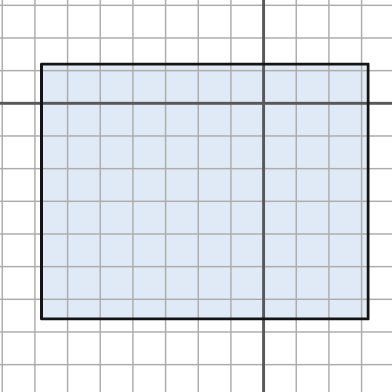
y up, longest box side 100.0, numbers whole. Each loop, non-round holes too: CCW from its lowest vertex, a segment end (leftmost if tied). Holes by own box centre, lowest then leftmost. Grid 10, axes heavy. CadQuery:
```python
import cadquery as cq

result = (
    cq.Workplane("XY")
    .moveTo(-68.0, -66.0)
    .lineTo(32.0, -66.0)
    .lineTo(32.0, 12.0)
    .lineTo(-68.0, 12.0)
    .close()
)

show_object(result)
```